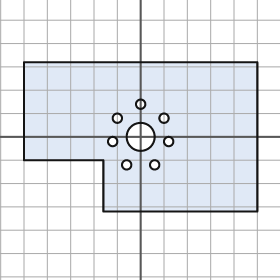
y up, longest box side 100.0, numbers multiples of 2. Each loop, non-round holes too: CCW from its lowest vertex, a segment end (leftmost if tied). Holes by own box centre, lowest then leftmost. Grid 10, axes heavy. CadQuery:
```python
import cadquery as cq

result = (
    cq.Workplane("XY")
    .moveTo(-16.0, -32.0)
    .lineTo(50.0, -32.0)
    .lineTo(50.0, 32.0)
    .lineTo(-50.0, 32.0)
    .lineTo(-50.0, -10.0)
    .lineTo(-16.0, -10.0)
    .close()
    .moveTo(-6.0, -12.0)
    .circle(2.0)
    .moveTo(6.0, -12.0)
    .circle(2.0)
    .moveTo(-12.0, -2.0)
    .circle(2.0)
    .moveTo(12.0, -2.0)
    .circle(2.0)
    .moveTo(0.0, 0.0)
    .circle(6.0)
    .moveTo(-10.0, 8.0)
    .circle(2.0)
    .moveTo(10.0, 8.0)
    .circle(2.0)
    .moveTo(0.0, 14.0)
    .circle(2.0)
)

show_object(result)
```